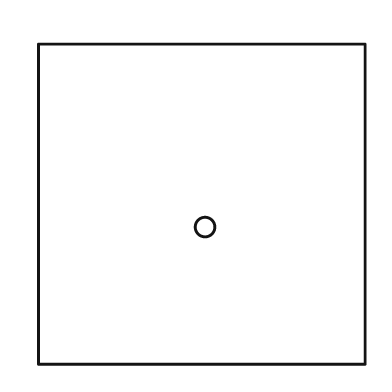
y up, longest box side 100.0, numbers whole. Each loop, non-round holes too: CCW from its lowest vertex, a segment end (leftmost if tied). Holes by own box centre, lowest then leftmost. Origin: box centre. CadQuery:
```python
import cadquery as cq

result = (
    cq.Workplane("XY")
    .moveTo(-50.0, -49.0)
    .lineTo(50.0, -49.0)
    .lineTo(50.0, 49.0)
    .lineTo(-50.0, 49.0)
    .close()
    .moveTo(1.0, -7.0)
    .circle(3.0)
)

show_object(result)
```